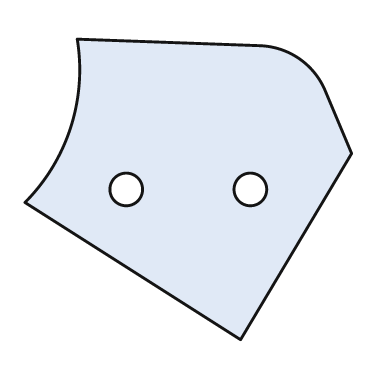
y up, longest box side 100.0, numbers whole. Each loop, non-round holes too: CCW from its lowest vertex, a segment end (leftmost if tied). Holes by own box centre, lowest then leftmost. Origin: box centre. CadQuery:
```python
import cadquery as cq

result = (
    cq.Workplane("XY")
    .moveTo(16.0, -46.0)
    .lineTo(50.0, 11.0)
    .lineTo(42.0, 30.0)
    .threePointArc((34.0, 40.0), (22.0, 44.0))
    .lineTo(-34.0, 46.0)
    .threePointArc((-36.0, 19.0), (-50.0, -4.0))
    .close()
    .moveTo(-19.0, 0.0)
    .circle(5.0)
    .moveTo(19.0, 0.0)
    .circle(5.0)
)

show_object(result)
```